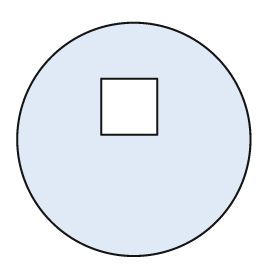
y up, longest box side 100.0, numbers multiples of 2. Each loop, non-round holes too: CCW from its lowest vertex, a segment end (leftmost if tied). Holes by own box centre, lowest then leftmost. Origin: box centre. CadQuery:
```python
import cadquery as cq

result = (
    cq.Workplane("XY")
    .moveTo(0.0, 0.0)
    .circle(50.0)
    .moveTo(-14.0, 2.0)
    .lineTo(10.0, 2.0)
    .lineTo(10.0, 26.0)
    .lineTo(-14.0, 26.0)
    .close()
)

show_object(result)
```